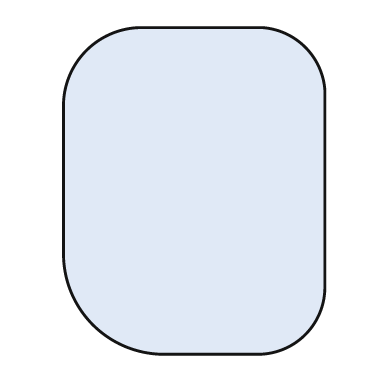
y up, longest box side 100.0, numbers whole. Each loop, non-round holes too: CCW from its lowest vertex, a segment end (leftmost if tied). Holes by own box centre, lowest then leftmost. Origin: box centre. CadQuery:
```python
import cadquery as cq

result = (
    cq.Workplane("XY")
    .moveTo(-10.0, -50.0)
    .lineTo(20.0, -50.0)
    .threePointArc((34.0, -44.0), (40.0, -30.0))
    .lineTo(40.0, 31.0)
    .threePointArc((34.0, 44.0), (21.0, 50.0))
    .lineTo(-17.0, 50.0)
    .threePointArc((-33.0, 43.0), (-40.0, 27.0))
    .lineTo(-40.0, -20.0)
    .threePointArc((-31.0, -41.0), (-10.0, -50.0))
    .close()
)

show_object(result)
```